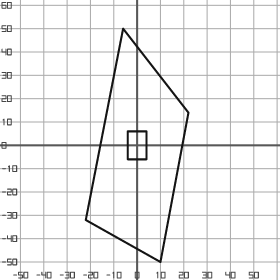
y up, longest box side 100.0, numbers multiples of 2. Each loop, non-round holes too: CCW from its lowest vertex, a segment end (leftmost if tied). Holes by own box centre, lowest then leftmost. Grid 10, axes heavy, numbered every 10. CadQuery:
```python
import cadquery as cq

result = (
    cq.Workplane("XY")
    .moveTo(10.0, -50.0)
    .lineTo(22.0, 14.0)
    .lineTo(-6.0, 50.0)
    .lineTo(-22.0, -32.0)
    .close()
    .moveTo(-4.0, -6.0)
    .lineTo(4.0, -6.0)
    .lineTo(4.0, 6.0)
    .lineTo(-4.0, 6.0)
    .close()
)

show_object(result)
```